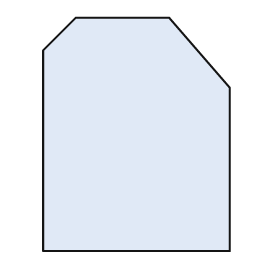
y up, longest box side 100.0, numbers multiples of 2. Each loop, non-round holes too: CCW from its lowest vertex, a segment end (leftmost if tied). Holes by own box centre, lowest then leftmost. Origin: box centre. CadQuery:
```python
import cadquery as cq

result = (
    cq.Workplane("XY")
    .moveTo(-40.0, -50.0)
    .lineTo(40.0, -50.0)
    .lineTo(40.0, 20.0)
    .lineTo(14.0, 50.0)
    .lineTo(-26.0, 50.0)
    .lineTo(-40.0, 36.0)
    .close()
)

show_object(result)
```